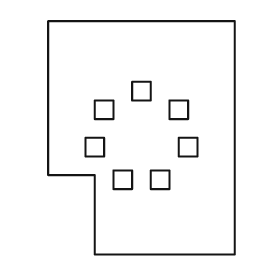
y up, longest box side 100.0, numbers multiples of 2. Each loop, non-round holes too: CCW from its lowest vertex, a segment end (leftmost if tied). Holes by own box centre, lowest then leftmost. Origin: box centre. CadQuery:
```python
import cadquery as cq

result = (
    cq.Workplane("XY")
    .moveTo(-20.0, -50.0)
    .lineTo(40.0, -50.0)
    .lineTo(40.0, 50.0)
    .lineTo(-40.0, 50.0)
    .lineTo(-40.0, -16.0)
    .lineTo(-20.0, -16.0)
    .close()
    .moveTo(-12.0, -22.0)
    .lineTo(-4.0, -22.0)
    .lineTo(-4.0, -14.0)
    .lineTo(-12.0, -14.0)
    .close()
    .moveTo(4.0, -22.0)
    .lineTo(12.0, -22.0)
    .lineTo(12.0, -14.0)
    .lineTo(4.0, -14.0)
    .close()
    .moveTo(-24.0, -8.0)
    .lineTo(-16.0, -8.0)
    .lineTo(-16.0, 0.0)
    .lineTo(-24.0, 0.0)
    .close()
    .moveTo(16.0, -8.0)
    .lineTo(24.0, -8.0)
    .lineTo(24.0, 0.0)
    .lineTo(16.0, 0.0)
    .close()
    .moveTo(-20.0, 8.0)
    .lineTo(-12.0, 8.0)
    .lineTo(-12.0, 16.0)
    .lineTo(-20.0, 16.0)
    .close()
    .moveTo(12.0, 8.0)
    .lineTo(20.0, 8.0)
    .lineTo(20.0, 16.0)
    .lineTo(12.0, 16.0)
    .close()
    .moveTo(-4.0, 16.0)
    .lineTo(4.0, 16.0)
    .lineTo(4.0, 24.0)
    .lineTo(-4.0, 24.0)
    .close()
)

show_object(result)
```